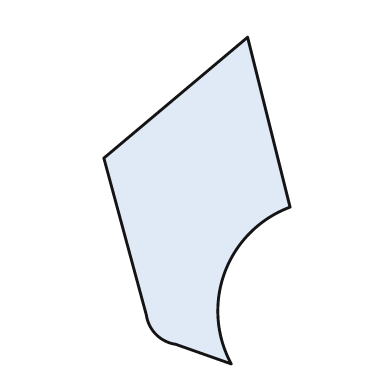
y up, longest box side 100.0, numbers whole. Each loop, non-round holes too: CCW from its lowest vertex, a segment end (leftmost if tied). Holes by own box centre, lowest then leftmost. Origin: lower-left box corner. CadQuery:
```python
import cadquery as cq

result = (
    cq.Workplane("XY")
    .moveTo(39.0, 0.0)
    .threePointArc((37.0, 28.0), (57.0, 48.0))
    .lineTo(44.0, 100.0)
    .lineTo(0.0, 63.0)
    .lineTo(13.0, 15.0)
    .threePointArc((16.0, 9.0), (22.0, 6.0))
    .close()
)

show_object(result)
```